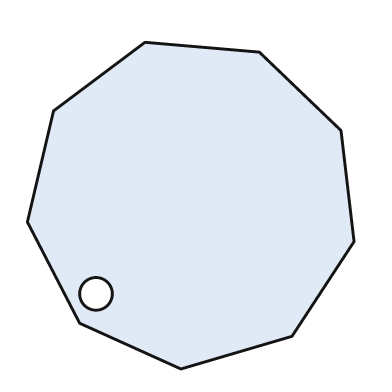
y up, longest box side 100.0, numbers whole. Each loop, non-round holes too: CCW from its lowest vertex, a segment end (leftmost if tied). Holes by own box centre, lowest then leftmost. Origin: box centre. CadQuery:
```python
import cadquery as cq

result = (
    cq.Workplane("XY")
    .moveTo(-3.0, -50.0)
    .lineTo(31.0, -40.0)
    .lineTo(50.0, -11.0)
    .lineTo(46.0, 23.0)
    .lineTo(21.0, 47.0)
    .lineTo(-14.0, 50.0)
    .lineTo(-42.0, 29.0)
    .lineTo(-50.0, -5.0)
    .lineTo(-34.0, -36.0)
    .close()
    .moveTo(-29.0, -27.0)
    .circle(5.0)
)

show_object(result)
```